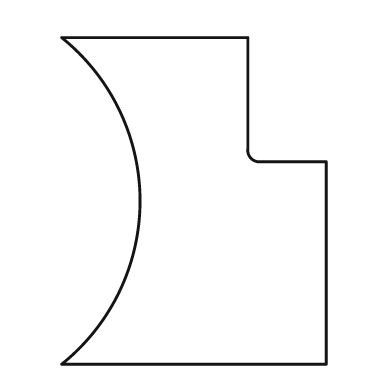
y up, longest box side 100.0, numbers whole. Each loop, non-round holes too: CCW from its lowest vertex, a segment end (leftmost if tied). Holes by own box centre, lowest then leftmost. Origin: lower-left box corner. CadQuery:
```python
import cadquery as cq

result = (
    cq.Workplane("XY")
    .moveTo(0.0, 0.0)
    .lineTo(81.0, 0.0)
    .lineTo(81.0, 62.0)
    .lineTo(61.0, 62.0)
    .threePointArc((58.0, 63.0), (57.0, 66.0))
    .lineTo(57.0, 100.0)
    .lineTo(0.0, 100.0)
    .threePointArc((24.0, 50.0), (0.0, 0.0))
    .close()
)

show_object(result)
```